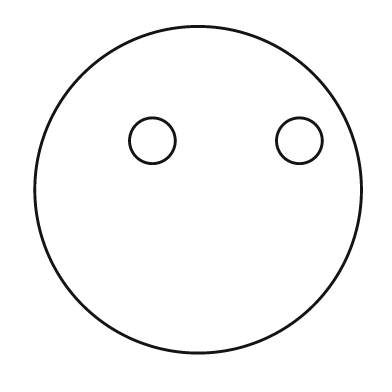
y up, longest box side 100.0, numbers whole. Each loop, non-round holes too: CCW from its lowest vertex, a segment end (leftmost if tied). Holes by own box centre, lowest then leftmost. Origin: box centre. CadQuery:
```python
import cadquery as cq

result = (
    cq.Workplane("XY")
    .moveTo(0.0, 0.0)
    .circle(50.0)
    .moveTo(-14.0, 15.0)
    .circle(7.0)
    .moveTo(31.0, 15.0)
    .circle(7.0)
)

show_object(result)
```